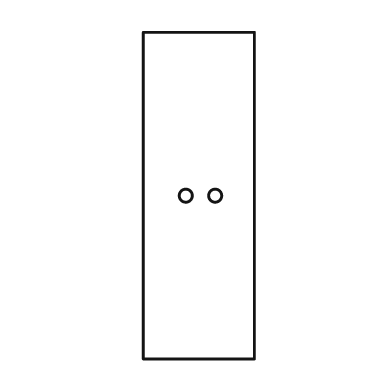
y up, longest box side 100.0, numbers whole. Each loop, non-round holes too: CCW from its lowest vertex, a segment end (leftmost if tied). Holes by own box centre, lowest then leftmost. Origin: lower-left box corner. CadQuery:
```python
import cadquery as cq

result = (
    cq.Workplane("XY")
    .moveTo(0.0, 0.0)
    .lineTo(34.0, 0.0)
    .lineTo(34.0, 100.0)
    .lineTo(0.0, 100.0)
    .close()
    .moveTo(13.0, 50.0)
    .circle(2.0)
    .moveTo(22.0, 50.0)
    .circle(2.0)
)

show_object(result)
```